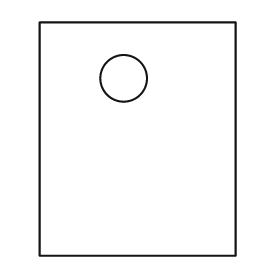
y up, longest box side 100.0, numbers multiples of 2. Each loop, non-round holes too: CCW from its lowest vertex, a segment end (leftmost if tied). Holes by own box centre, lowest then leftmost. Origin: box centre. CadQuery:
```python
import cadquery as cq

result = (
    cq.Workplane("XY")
    .moveTo(-42.0, -50.0)
    .lineTo(42.0, -50.0)
    .lineTo(42.0, 50.0)
    .lineTo(-42.0, 50.0)
    .close()
    .moveTo(-6.0, 26.0)
    .circle(10.0)
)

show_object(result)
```